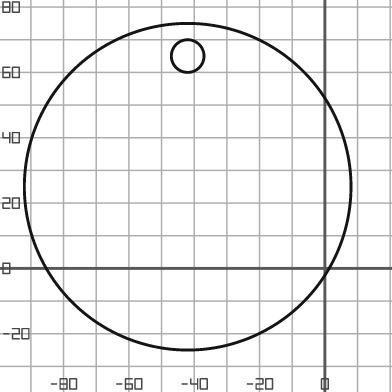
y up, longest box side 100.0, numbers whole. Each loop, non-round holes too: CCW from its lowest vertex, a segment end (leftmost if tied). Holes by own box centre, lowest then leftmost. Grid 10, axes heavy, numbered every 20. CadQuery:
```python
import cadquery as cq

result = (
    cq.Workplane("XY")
    .moveTo(-42.0, 25.0)
    .circle(50.0)
    .moveTo(-42.0, 65.0)
    .circle(5.0)
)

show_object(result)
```